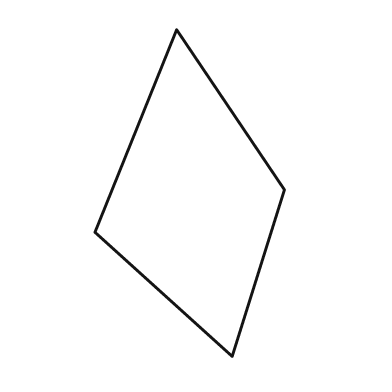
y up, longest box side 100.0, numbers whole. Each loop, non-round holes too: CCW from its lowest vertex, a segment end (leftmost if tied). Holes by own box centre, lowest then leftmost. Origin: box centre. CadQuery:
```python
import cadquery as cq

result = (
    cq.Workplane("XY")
    .moveTo(13.0, -50.0)
    .lineTo(29.0, 1.0)
    .lineTo(-4.0, 50.0)
    .lineTo(-29.0, -12.0)
    .close()
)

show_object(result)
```